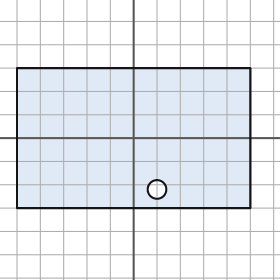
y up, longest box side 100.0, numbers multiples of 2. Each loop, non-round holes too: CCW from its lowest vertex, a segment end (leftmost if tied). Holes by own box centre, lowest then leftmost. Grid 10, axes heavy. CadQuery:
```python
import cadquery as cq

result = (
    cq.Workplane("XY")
    .moveTo(-50.0, -30.0)
    .lineTo(50.0, -30.0)
    .lineTo(50.0, 30.0)
    .lineTo(-50.0, 30.0)
    .close()
    .moveTo(10.0, -22.0)
    .circle(4.0)
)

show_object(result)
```